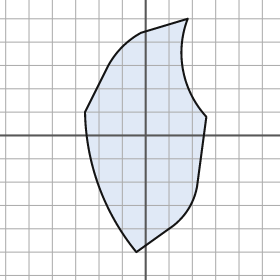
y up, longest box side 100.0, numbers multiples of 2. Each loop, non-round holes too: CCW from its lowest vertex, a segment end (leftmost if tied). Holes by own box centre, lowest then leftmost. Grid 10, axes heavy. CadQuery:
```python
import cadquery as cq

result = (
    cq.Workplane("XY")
    .moveTo(-4.0, -50.0)
    .lineTo(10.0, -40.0)
    .threePointArc((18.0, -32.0), (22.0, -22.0))
    .lineTo(26.0, 8.0)
    .threePointArc((16.0, 28.0), (18.0, 50.0))
    .lineTo(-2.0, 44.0)
    .threePointArc((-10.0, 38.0), (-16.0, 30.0))
    .lineTo(-26.0, 10.0)
    .threePointArc((-20.0, -22.0), (-4.0, -50.0))
    .close()
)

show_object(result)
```